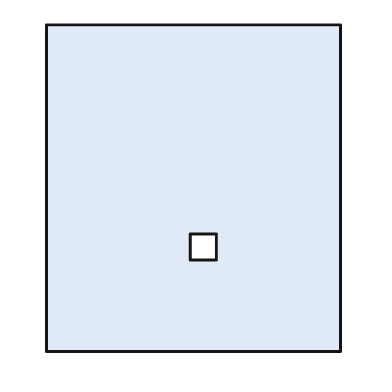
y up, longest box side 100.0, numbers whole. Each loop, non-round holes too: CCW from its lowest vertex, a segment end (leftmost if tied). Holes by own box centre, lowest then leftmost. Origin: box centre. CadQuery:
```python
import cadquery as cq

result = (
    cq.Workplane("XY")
    .moveTo(-45.0, -50.0)
    .lineTo(45.0, -50.0)
    .lineTo(45.0, 50.0)
    .lineTo(-45.0, 50.0)
    .close()
    .moveTo(-1.0, -22.0)
    .lineTo(7.0, -22.0)
    .lineTo(7.0, -14.0)
    .lineTo(-1.0, -14.0)
    .close()
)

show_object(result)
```